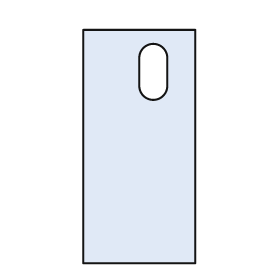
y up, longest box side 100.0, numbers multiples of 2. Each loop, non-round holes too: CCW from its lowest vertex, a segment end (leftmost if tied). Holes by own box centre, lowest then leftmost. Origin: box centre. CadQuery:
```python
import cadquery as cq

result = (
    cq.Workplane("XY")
    .moveTo(-24.0, -50.0)
    .lineTo(24.0, -50.0)
    .lineTo(24.0, 50.0)
    .lineTo(-24.0, 50.0)
    .close()
    .moveTo(0.0, 26.0)
    .threePointArc((6.0, 20.0), (12.0, 26.0))
    .lineTo(12.0, 38.0)
    .threePointArc((6.0, 44.0), (0.0, 38.0))
    .close()
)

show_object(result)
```